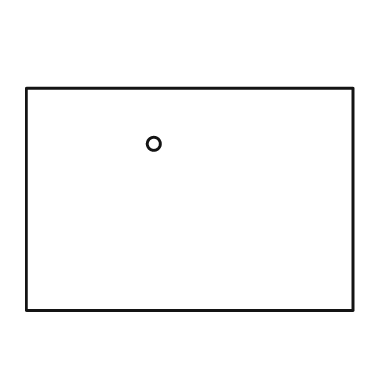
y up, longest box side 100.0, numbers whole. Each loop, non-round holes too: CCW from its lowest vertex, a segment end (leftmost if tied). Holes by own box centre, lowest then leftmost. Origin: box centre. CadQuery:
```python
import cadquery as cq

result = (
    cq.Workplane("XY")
    .moveTo(-50.0, -34.0)
    .lineTo(50.0, -34.0)
    .lineTo(50.0, 34.0)
    .lineTo(-50.0, 34.0)
    .close()
    .moveTo(-11.0, 17.0)
    .circle(2.0)
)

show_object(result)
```